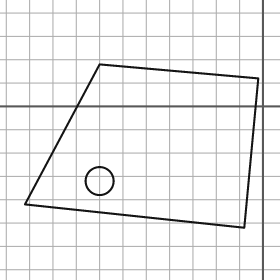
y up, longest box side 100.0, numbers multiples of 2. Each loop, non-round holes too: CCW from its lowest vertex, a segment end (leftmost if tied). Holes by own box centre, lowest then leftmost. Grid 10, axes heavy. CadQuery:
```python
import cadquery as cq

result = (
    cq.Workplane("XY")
    .moveTo(-8.0, -52.0)
    .lineTo(-2.0, 12.0)
    .lineTo(-70.0, 18.0)
    .lineTo(-102.0, -42.0)
    .close()
    .moveTo(-70.0, -32.0)
    .circle(6.0)
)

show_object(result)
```